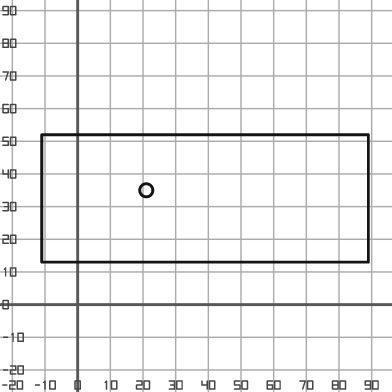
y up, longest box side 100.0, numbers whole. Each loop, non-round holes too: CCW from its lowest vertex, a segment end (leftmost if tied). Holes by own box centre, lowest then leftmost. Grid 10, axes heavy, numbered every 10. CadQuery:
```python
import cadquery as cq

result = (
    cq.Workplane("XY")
    .moveTo(-11.0, 13.0)
    .lineTo(89.0, 13.0)
    .lineTo(89.0, 52.0)
    .lineTo(-11.0, 52.0)
    .close()
    .moveTo(21.0, 35.0)
    .circle(2.0)
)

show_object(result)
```